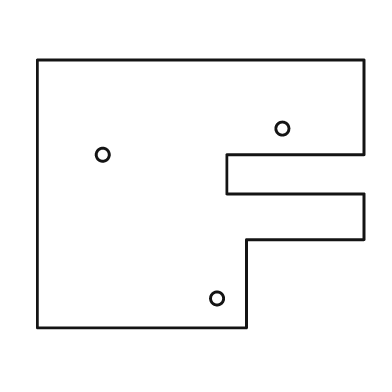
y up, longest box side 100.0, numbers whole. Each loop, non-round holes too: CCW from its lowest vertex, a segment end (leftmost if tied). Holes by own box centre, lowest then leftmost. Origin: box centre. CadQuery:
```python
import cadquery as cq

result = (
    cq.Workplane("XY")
    .moveTo(-50.0, -41.0)
    .lineTo(14.0, -41.0)
    .lineTo(14.0, -14.0)
    .lineTo(50.0, -14.0)
    .lineTo(50.0, 0.0)
    .lineTo(8.0, 0.0)
    .lineTo(8.0, 12.0)
    .lineTo(50.0, 12.0)
    .lineTo(50.0, 41.0)
    .lineTo(-50.0, 41.0)
    .close()
    .moveTo(5.0, -32.0)
    .circle(2.0)
    .moveTo(-30.0, 12.0)
    .circle(2.0)
    .moveTo(25.0, 20.0)
    .circle(2.0)
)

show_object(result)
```